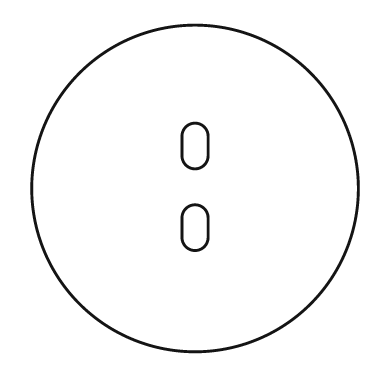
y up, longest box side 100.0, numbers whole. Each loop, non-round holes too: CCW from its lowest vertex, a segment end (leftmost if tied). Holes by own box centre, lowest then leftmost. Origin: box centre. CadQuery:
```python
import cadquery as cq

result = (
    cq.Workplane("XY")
    .moveTo(0.0, 0.0)
    .circle(50.0)
    .moveTo(-4.0, -15.0)
    .threePointArc((0.0, -19.0), (4.0, -15.0))
    .lineTo(4.0, -9.0)
    .threePointArc((0.0, -5.0), (-4.0, -9.0))
    .close()
    .moveTo(-4.0, 10.0)
    .threePointArc((0.0, 6.0), (4.0, 10.0))
    .lineTo(4.0, 16.0)
    .threePointArc((0.0, 20.0), (-4.0, 16.0))
    .close()
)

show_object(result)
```